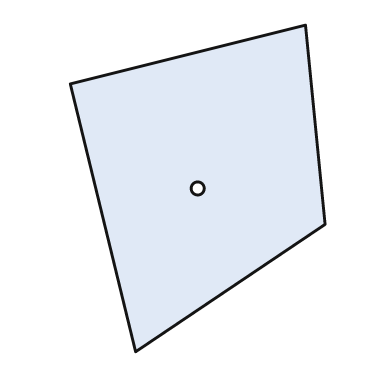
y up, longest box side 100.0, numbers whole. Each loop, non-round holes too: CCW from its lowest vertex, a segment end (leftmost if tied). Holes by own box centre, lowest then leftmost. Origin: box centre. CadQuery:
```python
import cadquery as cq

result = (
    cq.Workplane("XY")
    .moveTo(-19.0, -50.0)
    .lineTo(39.0, -11.0)
    .lineTo(33.0, 50.0)
    .lineTo(-39.0, 32.0)
    .close()
    .moveTo(0.0, 0.0)
    .circle(2.0)
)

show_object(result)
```